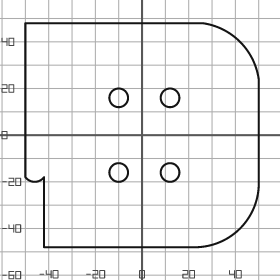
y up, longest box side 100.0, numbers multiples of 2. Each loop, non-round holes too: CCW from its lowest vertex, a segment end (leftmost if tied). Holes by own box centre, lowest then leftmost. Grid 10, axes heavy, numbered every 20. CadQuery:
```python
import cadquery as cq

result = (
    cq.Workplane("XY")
    .moveTo(-42.0, -48.0)
    .lineTo(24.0, -48.0)
    .threePointArc((42.0, -40.0), (50.0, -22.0))
    .lineTo(50.0, 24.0)
    .threePointArc((42.0, 40.0), (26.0, 48.0))
    .lineTo(-50.0, 48.0)
    .lineTo(-50.0, -18.0)
    .threePointArc((-46.0, -20.0), (-42.0, -18.0))
    .close()
    .moveTo(-10.0, -16.0)
    .circle(4.0)
    .moveTo(12.0, -16.0)
    .circle(4.0)
    .moveTo(-10.0, 16.0)
    .circle(4.0)
    .moveTo(12.0, 16.0)
    .circle(4.0)
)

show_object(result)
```